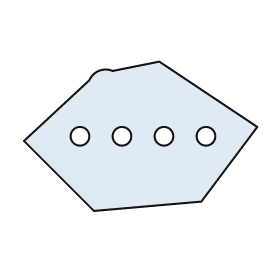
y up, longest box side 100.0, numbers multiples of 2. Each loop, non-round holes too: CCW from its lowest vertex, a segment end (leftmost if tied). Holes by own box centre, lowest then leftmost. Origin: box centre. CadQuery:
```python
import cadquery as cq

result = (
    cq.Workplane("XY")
    .moveTo(-20.0, -32.0)
    .lineTo(26.0, -28.0)
    .lineTo(50.0, 4.0)
    .lineTo(8.0, 32.0)
    .lineTo(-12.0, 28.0)
    .threePointArc((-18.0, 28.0), (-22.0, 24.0))
    .lineTo(-50.0, -2.0)
    .close()
    .moveTo(-26.0, 0.0)
    .circle(4.0)
    .moveTo(-8.0, 0.0)
    .circle(4.0)
    .moveTo(10.0, 0.0)
    .circle(4.0)
    .moveTo(28.0, 0.0)
    .circle(4.0)
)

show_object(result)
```